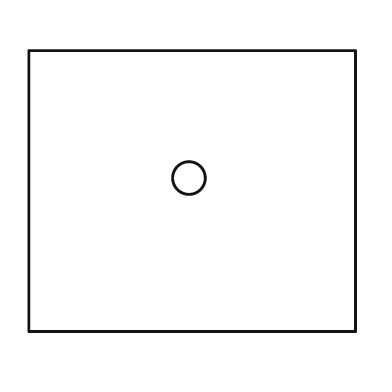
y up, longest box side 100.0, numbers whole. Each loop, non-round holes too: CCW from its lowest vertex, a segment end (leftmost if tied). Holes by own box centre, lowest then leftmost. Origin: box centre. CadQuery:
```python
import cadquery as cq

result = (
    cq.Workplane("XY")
    .moveTo(-50.0, -43.0)
    .lineTo(50.0, -43.0)
    .lineTo(50.0, 43.0)
    .lineTo(-50.0, 43.0)
    .close()
    .moveTo(-1.0, 4.0)
    .circle(5.0)
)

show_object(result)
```